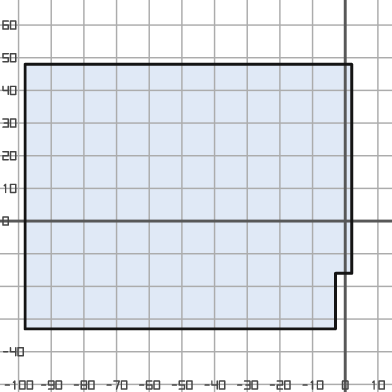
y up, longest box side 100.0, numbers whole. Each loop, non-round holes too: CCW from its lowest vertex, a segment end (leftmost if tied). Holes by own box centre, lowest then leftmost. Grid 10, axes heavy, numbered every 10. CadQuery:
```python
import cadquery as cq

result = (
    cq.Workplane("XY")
    .moveTo(-98.0, -33.0)
    .lineTo(-3.0, -33.0)
    .lineTo(-3.0, -16.0)
    .lineTo(2.0, -16.0)
    .lineTo(2.0, 48.0)
    .lineTo(-98.0, 48.0)
    .close()
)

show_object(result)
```